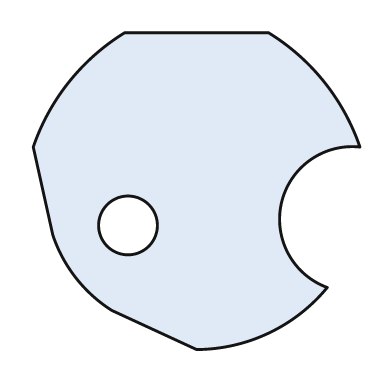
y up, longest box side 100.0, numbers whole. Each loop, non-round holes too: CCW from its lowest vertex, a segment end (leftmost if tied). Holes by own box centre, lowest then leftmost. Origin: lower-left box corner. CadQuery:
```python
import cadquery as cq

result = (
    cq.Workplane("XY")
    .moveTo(50.0, 0.0)
    .threePointArc((72.0, 5.0), (90.0, 19.0))
    .threePointArc((76.0, 45.0), (100.0, 62.0))
    .threePointArc((89.0, 82.0), (72.0, 97.0))
    .lineTo(28.0, 97.0)
    .threePointArc((11.0, 82.0), (0.0, 62.0))
    .lineTo(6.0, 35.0)
    .threePointArc((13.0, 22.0), (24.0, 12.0))
    .close()
    .moveTo(29.0, 38.0)
    .circle(9.0)
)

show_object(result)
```